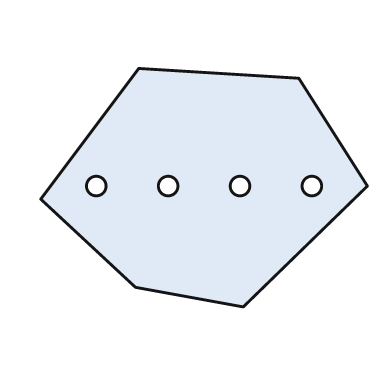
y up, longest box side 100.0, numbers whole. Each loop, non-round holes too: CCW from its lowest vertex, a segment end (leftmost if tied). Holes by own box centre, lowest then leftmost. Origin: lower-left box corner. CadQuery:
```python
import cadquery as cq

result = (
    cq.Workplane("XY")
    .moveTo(62.0, 0.0)
    .lineTo(100.0, 37.0)
    .lineTo(79.0, 70.0)
    .lineTo(30.0, 73.0)
    .lineTo(0.0, 33.0)
    .lineTo(29.0, 6.0)
    .close()
    .moveTo(17.0, 37.0)
    .circle(3.0)
    .moveTo(39.0, 37.0)
    .circle(3.0)
    .moveTo(61.0, 37.0)
    .circle(3.0)
    .moveTo(83.0, 37.0)
    .circle(3.0)
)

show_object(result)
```